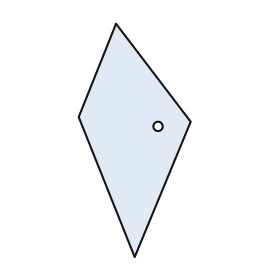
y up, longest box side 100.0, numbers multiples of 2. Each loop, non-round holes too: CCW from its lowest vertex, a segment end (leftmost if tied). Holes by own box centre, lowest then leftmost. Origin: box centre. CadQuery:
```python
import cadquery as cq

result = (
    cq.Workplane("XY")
    .moveTo(0.0, -50.0)
    .lineTo(24.0, 8.0)
    .lineTo(-8.0, 50.0)
    .lineTo(-24.0, 10.0)
    .close()
    .moveTo(10.0, 6.0)
    .circle(2.0)
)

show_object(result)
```